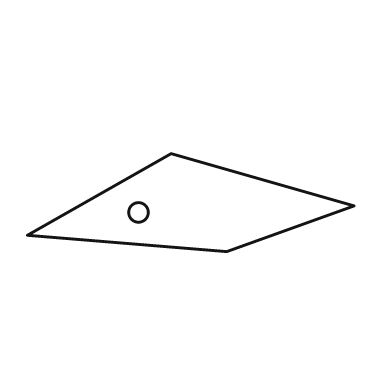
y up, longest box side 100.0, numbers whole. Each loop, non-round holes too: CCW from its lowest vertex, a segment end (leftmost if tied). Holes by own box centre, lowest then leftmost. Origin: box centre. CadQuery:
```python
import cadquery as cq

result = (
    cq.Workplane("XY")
    .moveTo(11.0, -15.0)
    .lineTo(50.0, -1.0)
    .lineTo(-6.0, 15.0)
    .lineTo(-50.0, -10.0)
    .close()
    .moveTo(-16.0, -3.0)
    .circle(3.0)
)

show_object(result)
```